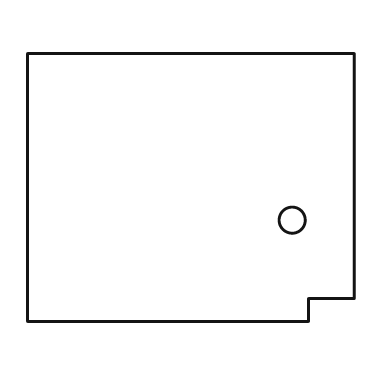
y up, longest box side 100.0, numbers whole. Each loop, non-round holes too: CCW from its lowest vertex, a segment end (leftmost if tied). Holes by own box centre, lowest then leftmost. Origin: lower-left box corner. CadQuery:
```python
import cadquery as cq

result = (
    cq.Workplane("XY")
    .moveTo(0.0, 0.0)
    .lineTo(86.0, 0.0)
    .lineTo(86.0, 7.0)
    .lineTo(100.0, 7.0)
    .lineTo(100.0, 82.0)
    .lineTo(0.0, 82.0)
    .close()
    .moveTo(81.0, 31.0)
    .circle(4.0)
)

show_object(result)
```